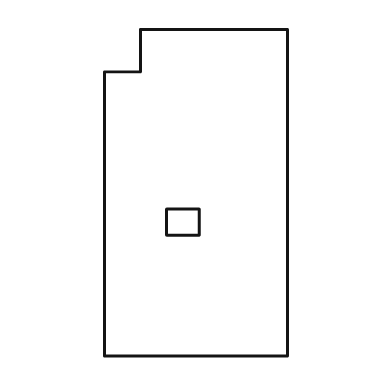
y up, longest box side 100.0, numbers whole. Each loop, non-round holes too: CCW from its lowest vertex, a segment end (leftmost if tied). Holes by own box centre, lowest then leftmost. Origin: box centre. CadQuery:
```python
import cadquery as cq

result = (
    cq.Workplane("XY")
    .moveTo(-28.0, -50.0)
    .lineTo(28.0, -50.0)
    .lineTo(28.0, 50.0)
    .lineTo(-17.0, 50.0)
    .lineTo(-17.0, 37.0)
    .lineTo(-28.0, 37.0)
    .close()
    .moveTo(-9.0, -13.0)
    .lineTo(1.0, -13.0)
    .lineTo(1.0, -5.0)
    .lineTo(-9.0, -5.0)
    .close()
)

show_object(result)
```